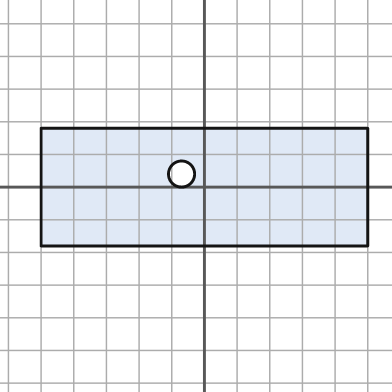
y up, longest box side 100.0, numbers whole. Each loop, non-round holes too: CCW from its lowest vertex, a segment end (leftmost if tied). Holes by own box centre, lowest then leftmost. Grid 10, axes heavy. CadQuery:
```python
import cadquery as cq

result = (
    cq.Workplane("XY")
    .moveTo(-50.0, -18.0)
    .lineTo(50.0, -18.0)
    .lineTo(50.0, 18.0)
    .lineTo(-50.0, 18.0)
    .close()
    .moveTo(-7.0, 4.0)
    .circle(4.0)
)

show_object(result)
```